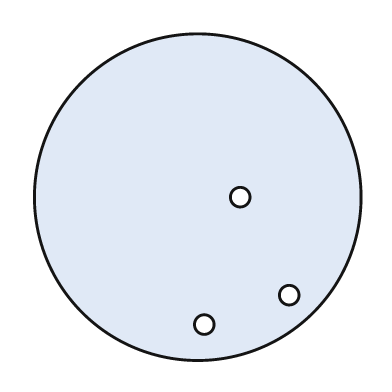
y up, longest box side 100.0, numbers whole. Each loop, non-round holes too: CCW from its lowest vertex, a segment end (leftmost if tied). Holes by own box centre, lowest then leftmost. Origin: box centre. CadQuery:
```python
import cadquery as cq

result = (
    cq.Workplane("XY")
    .moveTo(0.0, 0.0)
    .circle(50.0)
    .moveTo(2.0, -39.0)
    .circle(3.0)
    .moveTo(28.0, -30.0)
    .circle(3.0)
    .moveTo(13.0, 0.0)
    .circle(3.0)
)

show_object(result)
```